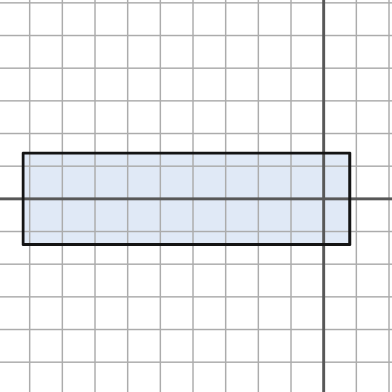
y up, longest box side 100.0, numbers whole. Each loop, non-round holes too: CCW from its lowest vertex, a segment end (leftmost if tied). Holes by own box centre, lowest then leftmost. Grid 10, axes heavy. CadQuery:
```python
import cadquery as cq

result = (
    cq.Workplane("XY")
    .moveTo(-92.0, -14.0)
    .lineTo(8.0, -14.0)
    .lineTo(8.0, 14.0)
    .lineTo(-92.0, 14.0)
    .close()
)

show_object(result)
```